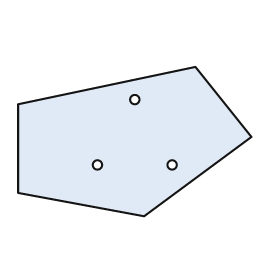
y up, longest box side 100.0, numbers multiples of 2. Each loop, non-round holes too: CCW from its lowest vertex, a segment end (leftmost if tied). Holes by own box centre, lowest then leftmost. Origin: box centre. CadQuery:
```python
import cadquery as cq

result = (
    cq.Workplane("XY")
    .moveTo(4.0, -32.0)
    .lineTo(50.0, 2.0)
    .lineTo(26.0, 32.0)
    .lineTo(-50.0, 16.0)
    .lineTo(-50.0, -22.0)
    .close()
    .moveTo(-16.0, -10.0)
    .circle(2.0)
    .moveTo(16.0, -10.0)
    .circle(2.0)
    .moveTo(0.0, 18.0)
    .circle(2.0)
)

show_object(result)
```